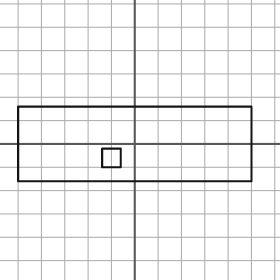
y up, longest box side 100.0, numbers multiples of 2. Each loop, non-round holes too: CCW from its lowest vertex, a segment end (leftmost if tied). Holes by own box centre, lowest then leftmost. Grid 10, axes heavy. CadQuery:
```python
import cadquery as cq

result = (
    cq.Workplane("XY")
    .moveTo(-50.0, -16.0)
    .lineTo(50.0, -16.0)
    .lineTo(50.0, 16.0)
    .lineTo(-50.0, 16.0)
    .close()
    .moveTo(-14.0, -10.0)
    .lineTo(-6.0, -10.0)
    .lineTo(-6.0, -2.0)
    .lineTo(-14.0, -2.0)
    .close()
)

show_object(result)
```